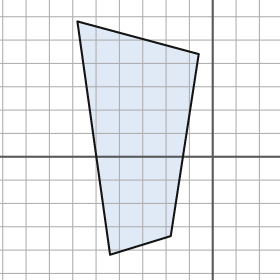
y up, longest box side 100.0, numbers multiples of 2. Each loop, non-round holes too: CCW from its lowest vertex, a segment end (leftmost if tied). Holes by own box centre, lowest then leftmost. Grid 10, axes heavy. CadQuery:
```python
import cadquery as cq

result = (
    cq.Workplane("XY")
    .moveTo(-44.0, -42.0)
    .lineTo(-18.0, -34.0)
    .lineTo(-6.0, 44.0)
    .lineTo(-58.0, 58.0)
    .close()
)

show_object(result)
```